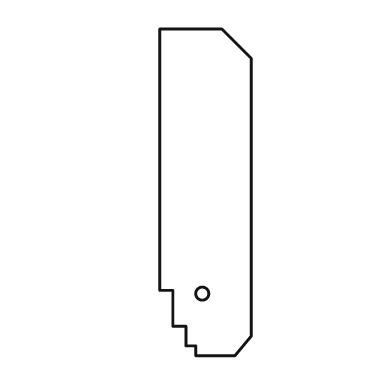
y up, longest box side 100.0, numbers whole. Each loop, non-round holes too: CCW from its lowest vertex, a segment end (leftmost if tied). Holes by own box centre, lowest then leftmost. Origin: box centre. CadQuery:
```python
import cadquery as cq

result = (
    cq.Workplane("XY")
    .moveTo(-3.0, -50.0)
    .lineTo(9.0, -50.0)
    .lineTo(14.0, -44.0)
    .lineTo(14.0, 41.0)
    .lineTo(5.0, 50.0)
    .lineTo(-14.0, 50.0)
    .lineTo(-14.0, -30.0)
    .lineTo(-10.0, -30.0)
    .lineTo(-10.0, -41.0)
    .lineTo(-6.0, -41.0)
    .lineTo(-6.0, -47.0)
    .lineTo(-3.0, -47.0)
    .close()
    .moveTo(-1.0, -31.0)
    .circle(2.0)
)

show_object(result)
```